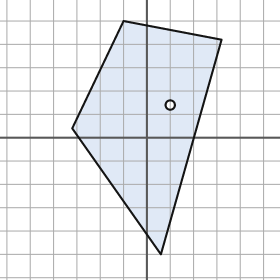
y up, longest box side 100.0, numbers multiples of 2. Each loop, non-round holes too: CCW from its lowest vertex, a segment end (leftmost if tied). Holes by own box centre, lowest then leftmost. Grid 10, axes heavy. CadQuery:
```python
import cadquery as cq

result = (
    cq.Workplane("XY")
    .moveTo(6.0, -50.0)
    .lineTo(32.0, 42.0)
    .lineTo(-10.0, 50.0)
    .lineTo(-32.0, 4.0)
    .close()
    .moveTo(10.0, 14.0)
    .circle(2.0)
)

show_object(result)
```